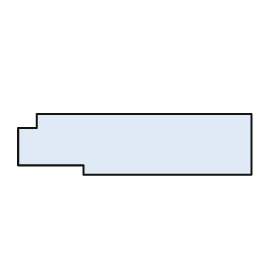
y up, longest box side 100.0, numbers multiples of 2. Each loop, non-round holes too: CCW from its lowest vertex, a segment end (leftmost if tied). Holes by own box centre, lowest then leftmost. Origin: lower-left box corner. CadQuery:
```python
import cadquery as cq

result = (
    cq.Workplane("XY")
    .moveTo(28.0, 0.0)
    .lineTo(100.0, 0.0)
    .lineTo(100.0, 26.0)
    .lineTo(8.0, 26.0)
    .lineTo(8.0, 20.0)
    .lineTo(0.0, 20.0)
    .lineTo(0.0, 4.0)
    .lineTo(28.0, 4.0)
    .close()
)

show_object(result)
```